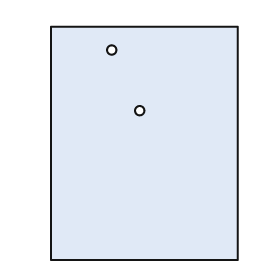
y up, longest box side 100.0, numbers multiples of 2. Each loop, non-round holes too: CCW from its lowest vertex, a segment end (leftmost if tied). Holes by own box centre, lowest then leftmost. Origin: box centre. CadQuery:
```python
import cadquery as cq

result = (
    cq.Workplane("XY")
    .moveTo(-40.0, -50.0)
    .lineTo(40.0, -50.0)
    .lineTo(40.0, 50.0)
    .lineTo(-40.0, 50.0)
    .close()
    .moveTo(-2.0, 14.0)
    .circle(2.0)
    .moveTo(-14.0, 40.0)
    .circle(2.0)
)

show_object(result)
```